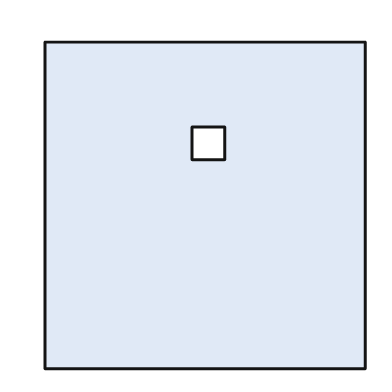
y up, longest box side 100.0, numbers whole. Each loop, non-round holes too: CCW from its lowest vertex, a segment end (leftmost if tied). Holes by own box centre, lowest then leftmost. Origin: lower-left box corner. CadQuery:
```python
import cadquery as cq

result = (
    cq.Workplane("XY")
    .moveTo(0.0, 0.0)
    .lineTo(98.0, 0.0)
    .lineTo(98.0, 100.0)
    .lineTo(0.0, 100.0)
    .close()
    .moveTo(45.0, 64.0)
    .lineTo(55.0, 64.0)
    .lineTo(55.0, 74.0)
    .lineTo(45.0, 74.0)
    .close()
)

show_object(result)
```